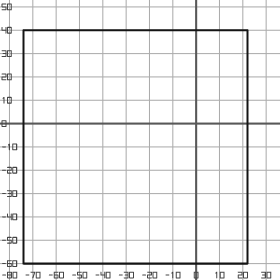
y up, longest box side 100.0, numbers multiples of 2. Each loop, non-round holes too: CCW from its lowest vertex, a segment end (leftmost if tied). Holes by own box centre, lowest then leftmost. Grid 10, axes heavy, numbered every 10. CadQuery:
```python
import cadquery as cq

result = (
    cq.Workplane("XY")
    .moveTo(-74.0, -60.0)
    .lineTo(22.0, -60.0)
    .lineTo(22.0, 40.0)
    .lineTo(-74.0, 40.0)
    .close()
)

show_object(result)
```